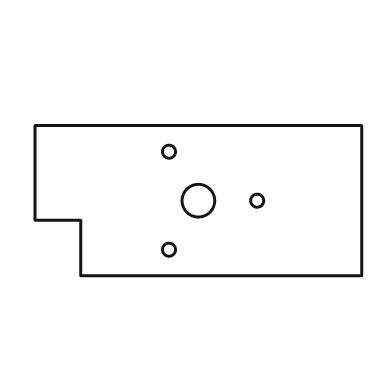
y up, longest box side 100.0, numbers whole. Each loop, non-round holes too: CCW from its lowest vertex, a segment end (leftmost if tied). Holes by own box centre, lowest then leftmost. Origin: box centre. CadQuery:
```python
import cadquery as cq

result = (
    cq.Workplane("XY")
    .moveTo(-36.0, -23.0)
    .lineTo(50.0, -23.0)
    .lineTo(50.0, 23.0)
    .lineTo(-50.0, 23.0)
    .lineTo(-50.0, -6.0)
    .lineTo(-36.0, -6.0)
    .close()
    .moveTo(-9.0, -15.0)
    .circle(2.0)
    .moveTo(0.0, 0.0)
    .circle(5.0)
    .moveTo(18.0, 0.0)
    .circle(2.0)
    .moveTo(-9.0, 15.0)
    .circle(2.0)
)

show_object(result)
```